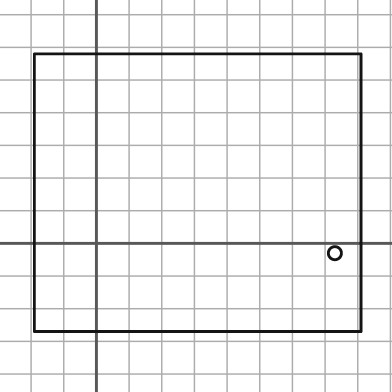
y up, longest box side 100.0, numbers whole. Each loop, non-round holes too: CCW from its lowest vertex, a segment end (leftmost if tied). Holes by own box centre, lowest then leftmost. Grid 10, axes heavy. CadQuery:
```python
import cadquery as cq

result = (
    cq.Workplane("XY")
    .moveTo(-19.0, -27.0)
    .lineTo(81.0, -27.0)
    .lineTo(81.0, 58.0)
    .lineTo(-19.0, 58.0)
    .close()
    .moveTo(73.0, -3.0)
    .circle(2.0)
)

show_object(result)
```